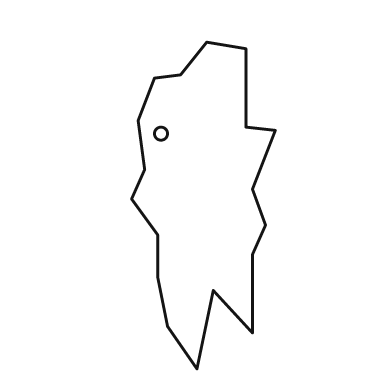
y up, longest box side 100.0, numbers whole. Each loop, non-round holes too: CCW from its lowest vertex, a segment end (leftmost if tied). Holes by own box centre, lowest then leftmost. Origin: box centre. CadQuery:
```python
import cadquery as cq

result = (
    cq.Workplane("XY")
    .moveTo(-2.0, -50.0)
    .lineTo(3.0, -26.0)
    .lineTo(15.0, -39.0)
    .lineTo(15.0, -15.0)
    .lineTo(19.0, -6.0)
    .lineTo(15.0, 5.0)
    .lineTo(22.0, 23.0)
    .lineTo(13.0, 24.0)
    .lineTo(13.0, 48.0)
    .lineTo(1.0, 50.0)
    .lineTo(-7.0, 40.0)
    .lineTo(-15.0, 39.0)
    .lineTo(-20.0, 26.0)
    .lineTo(-18.0, 11.0)
    .lineTo(-22.0, 2.0)
    .lineTo(-14.0, -9.0)
    .lineTo(-14.0, -22.0)
    .lineTo(-11.0, -37.0)
    .close()
    .moveTo(-13.0, 22.0)
    .circle(2.0)
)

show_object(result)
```